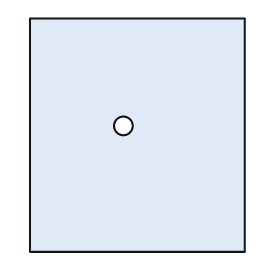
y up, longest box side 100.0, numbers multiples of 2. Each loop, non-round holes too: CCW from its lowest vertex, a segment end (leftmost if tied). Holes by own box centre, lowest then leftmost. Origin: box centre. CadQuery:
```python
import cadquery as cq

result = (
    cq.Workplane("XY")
    .moveTo(-46.0, -50.0)
    .lineTo(46.0, -50.0)
    .lineTo(46.0, 50.0)
    .lineTo(-46.0, 50.0)
    .close()
    .moveTo(-6.0, 4.0)
    .circle(4.0)
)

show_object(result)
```